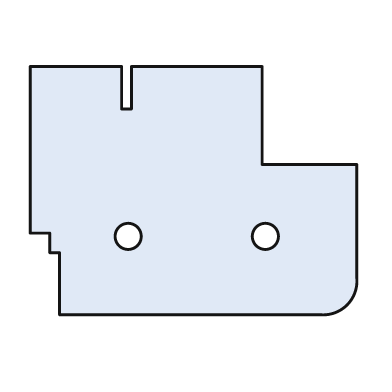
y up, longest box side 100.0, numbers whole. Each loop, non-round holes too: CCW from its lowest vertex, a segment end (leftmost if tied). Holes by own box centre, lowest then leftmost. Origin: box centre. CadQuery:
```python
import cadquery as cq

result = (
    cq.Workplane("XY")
    .moveTo(-41.0, -38.0)
    .lineTo(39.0, -38.0)
    .threePointArc((47.0, -35.0), (50.0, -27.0))
    .lineTo(50.0, 8.0)
    .lineTo(21.0, 8.0)
    .lineTo(21.0, 38.0)
    .lineTo(-19.0, 38.0)
    .lineTo(-19.0, 25.0)
    .lineTo(-22.0, 25.0)
    .lineTo(-22.0, 38.0)
    .lineTo(-50.0, 38.0)
    .lineTo(-50.0, -13.0)
    .lineTo(-44.0, -13.0)
    .lineTo(-44.0, -19.0)
    .lineTo(-41.0, -19.0)
    .close()
    .moveTo(-20.0, -14.0)
    .circle(4.0)
    .moveTo(22.0, -14.0)
    .circle(4.0)
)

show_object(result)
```